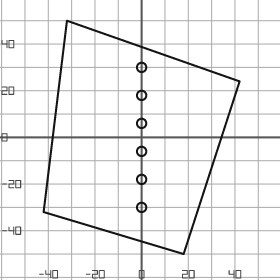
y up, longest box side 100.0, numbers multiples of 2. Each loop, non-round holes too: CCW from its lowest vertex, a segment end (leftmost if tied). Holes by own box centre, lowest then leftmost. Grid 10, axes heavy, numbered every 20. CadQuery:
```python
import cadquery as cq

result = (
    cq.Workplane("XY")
    .moveTo(18.0, -50.0)
    .lineTo(42.0, 24.0)
    .lineTo(-32.0, 50.0)
    .lineTo(-42.0, -32.0)
    .close()
    .moveTo(0.0, -30.0)
    .circle(2.0)
    .moveTo(0.0, -18.0)
    .circle(2.0)
    .moveTo(0.0, -6.0)
    .circle(2.0)
    .moveTo(0.0, 6.0)
    .circle(2.0)
    .moveTo(0.0, 18.0)
    .circle(2.0)
    .moveTo(0.0, 30.0)
    .circle(2.0)
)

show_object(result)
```